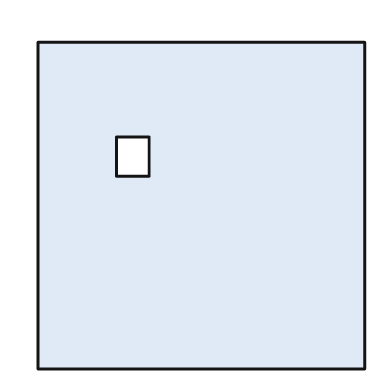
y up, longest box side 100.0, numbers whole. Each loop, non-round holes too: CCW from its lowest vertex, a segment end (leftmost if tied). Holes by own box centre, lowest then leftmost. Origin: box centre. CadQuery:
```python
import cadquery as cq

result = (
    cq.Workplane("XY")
    .moveTo(-50.0, -50.0)
    .lineTo(50.0, -50.0)
    .lineTo(50.0, 50.0)
    .lineTo(-50.0, 50.0)
    .close()
    .moveTo(-26.0, 9.0)
    .lineTo(-16.0, 9.0)
    .lineTo(-16.0, 21.0)
    .lineTo(-26.0, 21.0)
    .close()
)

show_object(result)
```